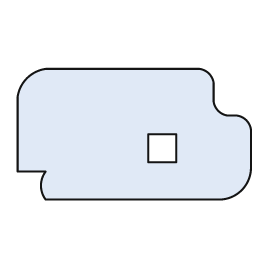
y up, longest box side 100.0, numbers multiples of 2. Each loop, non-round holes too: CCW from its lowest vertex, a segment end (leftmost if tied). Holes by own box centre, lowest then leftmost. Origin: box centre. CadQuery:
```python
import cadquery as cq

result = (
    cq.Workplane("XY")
    .moveTo(-38.0, -28.0)
    .lineTo(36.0, -28.0)
    .threePointArc((46.0, -24.0), (50.0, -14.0))
    .lineTo(50.0, 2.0)
    .threePointArc((48.0, 6.0), (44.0, 8.0))
    .lineTo(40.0, 8.0)
    .threePointArc((36.0, 10.0), (34.0, 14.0))
    .lineTo(34.0, 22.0)
    .threePointArc((32.0, 26.0), (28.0, 28.0))
    .lineTo(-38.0, 28.0)
    .threePointArc((-46.0, 24.0), (-50.0, 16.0))
    .lineTo(-50.0, -16.0)
    .lineTo(-38.0, -16.0)
    .threePointArc((-40.0, -22.0), (-38.0, -28.0))
    .close()
    .moveTo(6.0, -12.0)
    .lineTo(18.0, -12.0)
    .lineTo(18.0, 0.0)
    .lineTo(6.0, 0.0)
    .close()
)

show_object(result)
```